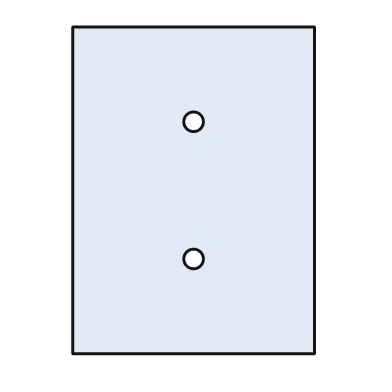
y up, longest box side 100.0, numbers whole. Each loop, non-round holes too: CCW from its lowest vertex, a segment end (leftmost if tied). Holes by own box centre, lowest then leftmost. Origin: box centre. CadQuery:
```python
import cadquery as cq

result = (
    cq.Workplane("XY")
    .moveTo(-37.0, -50.0)
    .lineTo(37.0, -50.0)
    .lineTo(37.0, 50.0)
    .lineTo(-37.0, 50.0)
    .close()
    .moveTo(0.0, -21.0)
    .circle(3.0)
    .moveTo(0.0, 21.0)
    .circle(3.0)
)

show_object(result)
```